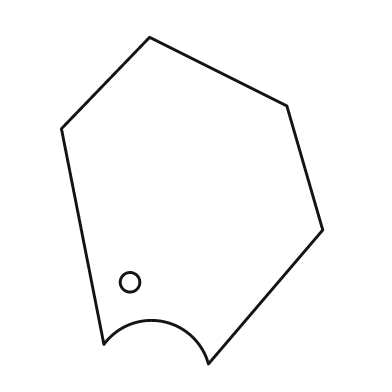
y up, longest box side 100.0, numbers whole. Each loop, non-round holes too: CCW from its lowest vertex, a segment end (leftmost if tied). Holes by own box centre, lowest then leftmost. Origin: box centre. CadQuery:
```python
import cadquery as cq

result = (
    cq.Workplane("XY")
    .moveTo(5.0, -50.0)
    .lineTo(40.0, -9.0)
    .lineTo(29.0, 29.0)
    .lineTo(-13.0, 50.0)
    .lineTo(-40.0, 22.0)
    .lineTo(-27.0, -44.0)
    .threePointArc((-9.0, -37.0), (5.0, -50.0))
    .close()
    .moveTo(-19.0, -25.0)
    .circle(3.0)
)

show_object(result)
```